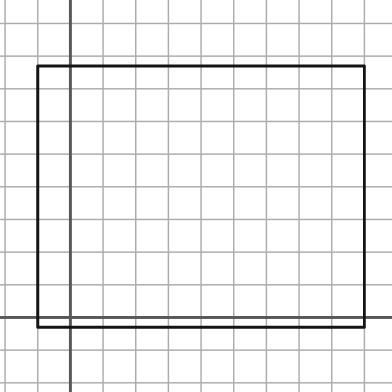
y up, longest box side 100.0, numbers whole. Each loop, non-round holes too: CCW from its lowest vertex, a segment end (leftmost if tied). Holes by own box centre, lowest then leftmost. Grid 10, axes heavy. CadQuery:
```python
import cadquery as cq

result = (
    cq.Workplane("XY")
    .moveTo(-10.0, -3.0)
    .lineTo(90.0, -3.0)
    .lineTo(90.0, 77.0)
    .lineTo(-10.0, 77.0)
    .close()
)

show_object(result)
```